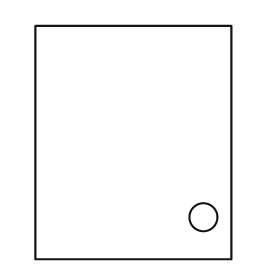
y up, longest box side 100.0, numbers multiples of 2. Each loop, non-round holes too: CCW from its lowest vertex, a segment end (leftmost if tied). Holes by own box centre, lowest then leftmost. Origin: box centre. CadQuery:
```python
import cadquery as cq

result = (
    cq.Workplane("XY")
    .moveTo(-42.0, -50.0)
    .lineTo(42.0, -50.0)
    .lineTo(42.0, 50.0)
    .lineTo(-42.0, 50.0)
    .close()
    .moveTo(30.0, -32.0)
    .circle(6.0)
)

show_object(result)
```